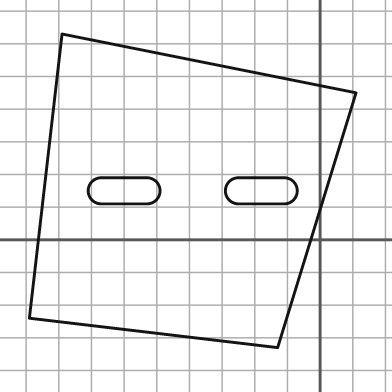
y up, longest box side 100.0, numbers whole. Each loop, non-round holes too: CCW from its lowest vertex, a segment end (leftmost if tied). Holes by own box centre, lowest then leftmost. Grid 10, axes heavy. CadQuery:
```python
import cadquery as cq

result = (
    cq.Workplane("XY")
    .moveTo(-13.0, -33.0)
    .lineTo(11.0, 45.0)
    .lineTo(-79.0, 63.0)
    .lineTo(-89.0, -24.0)
    .close()
    .moveTo(-67.0, 11.0)
    .lineTo(-53.0, 11.0)
    .threePointArc((-49.0, 15.0), (-53.0, 19.0))
    .lineTo(-67.0, 19.0)
    .threePointArc((-71.0, 15.0), (-67.0, 11.0))
    .close()
    .moveTo(-25.0, 11.0)
    .lineTo(-11.0, 11.0)
    .threePointArc((-7.0, 15.0), (-11.0, 19.0))
    .lineTo(-25.0, 19.0)
    .threePointArc((-29.0, 15.0), (-25.0, 11.0))
    .close()
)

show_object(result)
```